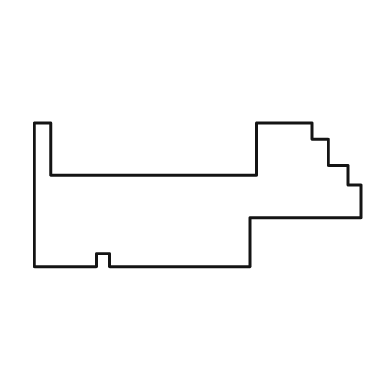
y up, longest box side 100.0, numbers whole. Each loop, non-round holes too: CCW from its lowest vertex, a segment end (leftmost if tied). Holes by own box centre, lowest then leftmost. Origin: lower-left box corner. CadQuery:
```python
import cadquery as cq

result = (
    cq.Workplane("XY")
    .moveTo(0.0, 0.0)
    .lineTo(19.0, 0.0)
    .lineTo(19.0, 4.0)
    .lineTo(23.0, 4.0)
    .lineTo(23.0, 0.0)
    .lineTo(66.0, 0.0)
    .lineTo(66.0, 15.0)
    .lineTo(100.0, 15.0)
    .lineTo(100.0, 25.0)
    .lineTo(96.0, 25.0)
    .lineTo(96.0, 31.0)
    .lineTo(90.0, 31.0)
    .lineTo(90.0, 39.0)
    .lineTo(85.0, 39.0)
    .lineTo(85.0, 44.0)
    .lineTo(68.0, 44.0)
    .lineTo(68.0, 28.0)
    .lineTo(5.0, 28.0)
    .lineTo(5.0, 44.0)
    .lineTo(0.0, 44.0)
    .close()
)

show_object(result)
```